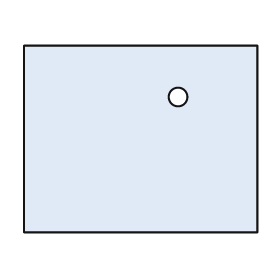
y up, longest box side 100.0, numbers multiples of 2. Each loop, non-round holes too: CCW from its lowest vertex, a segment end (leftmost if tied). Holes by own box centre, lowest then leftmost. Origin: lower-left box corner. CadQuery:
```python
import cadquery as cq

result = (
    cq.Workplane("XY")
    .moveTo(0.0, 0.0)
    .lineTo(100.0, 0.0)
    .lineTo(100.0, 80.0)
    .lineTo(0.0, 80.0)
    .close()
    .moveTo(66.0, 58.0)
    .circle(4.0)
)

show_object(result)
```